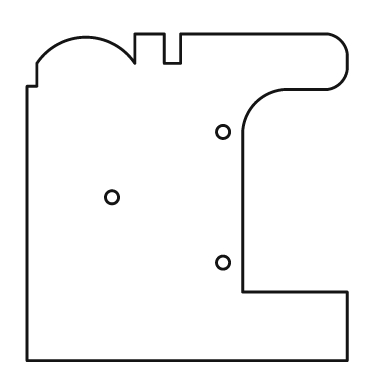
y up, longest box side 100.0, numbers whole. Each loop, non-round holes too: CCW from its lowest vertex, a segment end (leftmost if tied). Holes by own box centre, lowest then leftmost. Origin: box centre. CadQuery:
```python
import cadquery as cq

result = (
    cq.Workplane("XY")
    .moveTo(-49.0, -50.0)
    .lineTo(49.0, -50.0)
    .lineTo(49.0, -29.0)
    .lineTo(17.0, -29.0)
    .lineTo(17.0, 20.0)
    .threePointArc((21.0, 29.0), (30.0, 33.0))
    .lineTo(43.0, 33.0)
    .threePointArc((47.0, 35.0), (49.0, 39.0))
    .lineTo(49.0, 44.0)
    .threePointArc((47.0, 48.0), (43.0, 50.0))
    .lineTo(-2.0, 50.0)
    .lineTo(-2.0, 41.0)
    .lineTo(-7.0, 41.0)
    .lineTo(-7.0, 50.0)
    .lineTo(-16.0, 50.0)
    .lineTo(-16.0, 41.0)
    .threePointArc((-31.0, 49.0), (-46.0, 41.0))
    .lineTo(-46.0, 34.0)
    .lineTo(-49.0, 34.0)
    .close()
    .moveTo(11.0, -20.0)
    .circle(2.0)
    .moveTo(-23.0, 0.0)
    .circle(2.0)
    .moveTo(11.0, 20.0)
    .circle(2.0)
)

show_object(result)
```